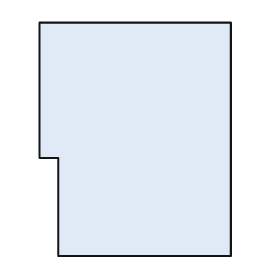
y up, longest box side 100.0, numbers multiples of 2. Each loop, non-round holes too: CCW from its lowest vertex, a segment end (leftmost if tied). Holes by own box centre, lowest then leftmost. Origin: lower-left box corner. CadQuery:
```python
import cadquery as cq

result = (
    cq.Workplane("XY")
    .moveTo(8.0, 0.0)
    .lineTo(82.0, 0.0)
    .lineTo(82.0, 100.0)
    .lineTo(0.0, 100.0)
    .lineTo(0.0, 42.0)
    .lineTo(8.0, 42.0)
    .close()
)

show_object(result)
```